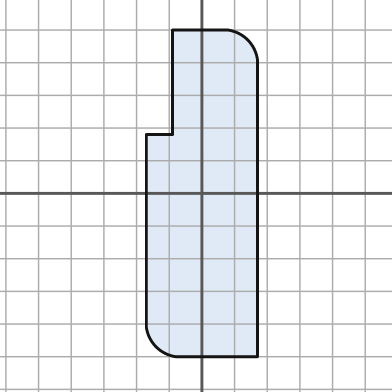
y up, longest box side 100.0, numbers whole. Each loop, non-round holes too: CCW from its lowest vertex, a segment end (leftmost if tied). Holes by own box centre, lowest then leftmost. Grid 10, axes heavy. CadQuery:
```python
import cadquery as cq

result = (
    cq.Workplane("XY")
    .moveTo(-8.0, -50.0)
    .lineTo(17.0, -50.0)
    .lineTo(17.0, 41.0)
    .threePointArc((14.0, 47.0), (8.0, 50.0))
    .lineTo(-9.0, 50.0)
    .lineTo(-9.0, 18.0)
    .lineTo(-17.0, 18.0)
    .lineTo(-17.0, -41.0)
    .threePointArc((-14.0, -47.0), (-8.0, -50.0))
    .close()
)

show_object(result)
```